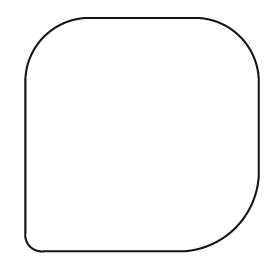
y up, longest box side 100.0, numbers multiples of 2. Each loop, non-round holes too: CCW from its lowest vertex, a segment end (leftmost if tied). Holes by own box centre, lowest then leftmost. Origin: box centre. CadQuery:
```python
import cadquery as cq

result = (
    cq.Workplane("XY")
    .moveTo(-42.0, -50.0)
    .lineTo(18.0, -50.0)
    .threePointArc((40.0, -40.0), (50.0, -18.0))
    .lineTo(50.0, 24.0)
    .threePointArc((42.0, 42.0), (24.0, 50.0))
    .lineTo(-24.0, 50.0)
    .threePointArc((-42.0, 42.0), (-50.0, 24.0))
    .lineTo(-50.0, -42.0)
    .threePointArc((-48.0, -48.0), (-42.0, -50.0))
    .close()
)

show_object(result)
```